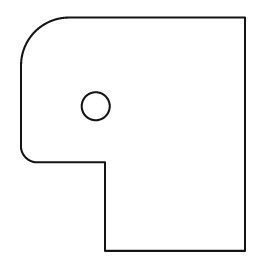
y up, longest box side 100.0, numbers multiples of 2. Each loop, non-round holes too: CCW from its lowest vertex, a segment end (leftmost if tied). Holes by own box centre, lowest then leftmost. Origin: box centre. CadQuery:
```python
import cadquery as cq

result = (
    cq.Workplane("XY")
    .moveTo(-12.0, -50.0)
    .lineTo(48.0, -50.0)
    .lineTo(48.0, 50.0)
    .lineTo(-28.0, 50.0)
    .threePointArc((-42.0, 44.0), (-48.0, 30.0))
    .lineTo(-48.0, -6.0)
    .threePointArc((-46.0, -10.0), (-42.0, -12.0))
    .lineTo(-12.0, -12.0)
    .close()
    .moveTo(-16.0, 12.0)
    .circle(6.0)
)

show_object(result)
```